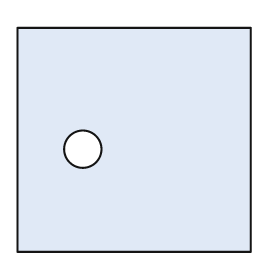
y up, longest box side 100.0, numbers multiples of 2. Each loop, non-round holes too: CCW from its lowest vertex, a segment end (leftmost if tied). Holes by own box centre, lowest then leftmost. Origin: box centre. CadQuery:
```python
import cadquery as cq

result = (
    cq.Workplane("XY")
    .moveTo(-50.0, -48.0)
    .lineTo(50.0, -48.0)
    .lineTo(50.0, 48.0)
    .lineTo(-50.0, 48.0)
    .close()
    .moveTo(-22.0, -4.0)
    .circle(8.0)
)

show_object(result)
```